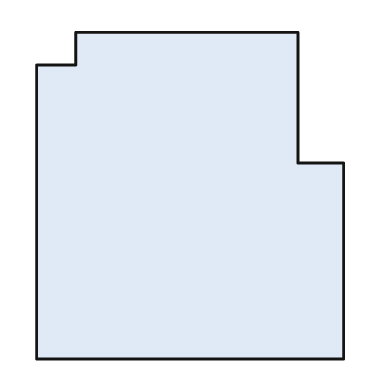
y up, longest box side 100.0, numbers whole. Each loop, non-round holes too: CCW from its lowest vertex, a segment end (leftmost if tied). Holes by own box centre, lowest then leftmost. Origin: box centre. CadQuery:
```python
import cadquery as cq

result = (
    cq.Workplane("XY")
    .moveTo(-47.0, -50.0)
    .lineTo(47.0, -50.0)
    .lineTo(47.0, 10.0)
    .lineTo(33.0, 10.0)
    .lineTo(33.0, 50.0)
    .lineTo(-35.0, 50.0)
    .lineTo(-35.0, 40.0)
    .lineTo(-47.0, 40.0)
    .close()
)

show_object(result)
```